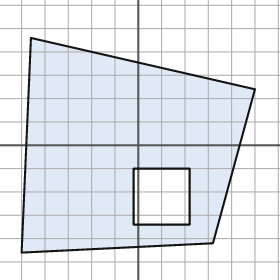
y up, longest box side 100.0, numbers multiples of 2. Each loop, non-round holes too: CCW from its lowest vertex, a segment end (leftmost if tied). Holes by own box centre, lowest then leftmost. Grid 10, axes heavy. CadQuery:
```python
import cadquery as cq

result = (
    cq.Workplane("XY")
    .moveTo(-50.0, -46.0)
    .lineTo(32.0, -42.0)
    .lineTo(50.0, 24.0)
    .lineTo(-46.0, 46.0)
    .close()
    .moveTo(-2.0, -34.0)
    .lineTo(22.0, -34.0)
    .lineTo(22.0, -10.0)
    .lineTo(-2.0, -10.0)
    .close()
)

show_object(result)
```